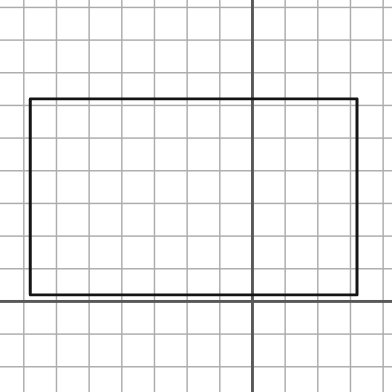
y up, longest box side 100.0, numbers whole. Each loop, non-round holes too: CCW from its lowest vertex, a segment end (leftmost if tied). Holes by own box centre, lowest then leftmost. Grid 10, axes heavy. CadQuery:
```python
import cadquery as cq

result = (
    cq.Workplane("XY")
    .moveTo(-68.0, 2.0)
    .lineTo(32.0, 2.0)
    .lineTo(32.0, 62.0)
    .lineTo(-68.0, 62.0)
    .close()
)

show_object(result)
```